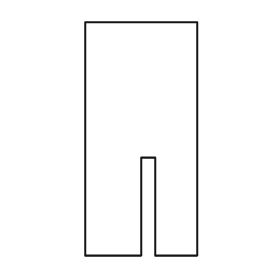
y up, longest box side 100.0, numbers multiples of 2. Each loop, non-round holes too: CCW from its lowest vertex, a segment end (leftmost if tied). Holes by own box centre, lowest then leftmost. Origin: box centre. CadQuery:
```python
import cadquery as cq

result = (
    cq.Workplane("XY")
    .moveTo(-24.0, -50.0)
    .lineTo(0.0, -50.0)
    .lineTo(0.0, -8.0)
    .lineTo(6.0, -8.0)
    .lineTo(6.0, -50.0)
    .lineTo(24.0, -50.0)
    .lineTo(24.0, 50.0)
    .lineTo(-24.0, 50.0)
    .close()
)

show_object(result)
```